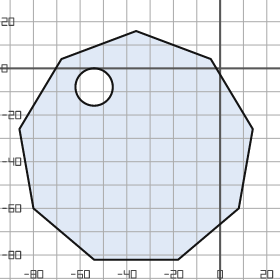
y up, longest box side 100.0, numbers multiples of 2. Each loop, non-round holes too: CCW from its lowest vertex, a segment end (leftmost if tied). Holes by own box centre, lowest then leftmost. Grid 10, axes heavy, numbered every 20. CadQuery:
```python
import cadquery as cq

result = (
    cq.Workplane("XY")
    .moveTo(-54.0, -82.0)
    .lineTo(-18.0, -82.0)
    .lineTo(8.0, -60.0)
    .lineTo(14.0, -26.0)
    .lineTo(-4.0, 4.0)
    .lineTo(-36.0, 16.0)
    .lineTo(-68.0, 4.0)
    .lineTo(-86.0, -26.0)
    .lineTo(-80.0, -60.0)
    .close()
    .moveTo(-54.0, -8.0)
    .circle(8.0)
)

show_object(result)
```